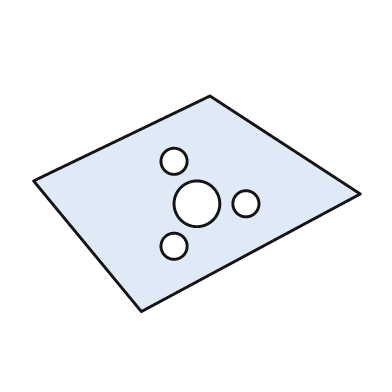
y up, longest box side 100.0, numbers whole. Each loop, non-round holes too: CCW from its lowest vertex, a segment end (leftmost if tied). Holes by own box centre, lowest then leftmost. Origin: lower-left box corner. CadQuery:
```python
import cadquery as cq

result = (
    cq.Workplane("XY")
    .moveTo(33.0, 0.0)
    .lineTo(100.0, 36.0)
    .lineTo(54.0, 66.0)
    .lineTo(0.0, 40.0)
    .close()
    .moveTo(43.0, 20.0)
    .circle(4.0)
    .moveTo(50.0, 33.0)
    .circle(7.0)
    .moveTo(65.0, 33.0)
    .circle(4.0)
    .moveTo(43.0, 46.0)
    .circle(4.0)
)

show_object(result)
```